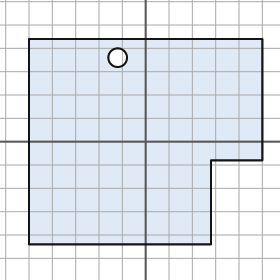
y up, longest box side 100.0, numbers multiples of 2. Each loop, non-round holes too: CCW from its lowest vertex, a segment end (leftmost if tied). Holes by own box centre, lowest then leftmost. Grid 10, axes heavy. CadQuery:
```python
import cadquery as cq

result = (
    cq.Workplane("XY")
    .moveTo(-50.0, -44.0)
    .lineTo(28.0, -44.0)
    .lineTo(28.0, -8.0)
    .lineTo(50.0, -8.0)
    .lineTo(50.0, 44.0)
    .lineTo(-50.0, 44.0)
    .close()
    .moveTo(-12.0, 36.0)
    .circle(4.0)
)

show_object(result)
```